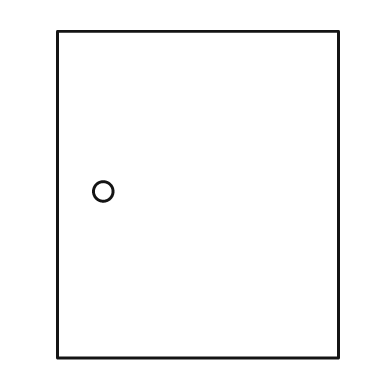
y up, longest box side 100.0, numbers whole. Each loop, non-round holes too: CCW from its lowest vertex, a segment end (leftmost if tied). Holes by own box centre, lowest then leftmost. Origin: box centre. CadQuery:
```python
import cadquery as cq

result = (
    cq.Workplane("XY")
    .moveTo(-43.0, -50.0)
    .lineTo(43.0, -50.0)
    .lineTo(43.0, 50.0)
    .lineTo(-43.0, 50.0)
    .close()
    .moveTo(-29.0, 1.0)
    .circle(3.0)
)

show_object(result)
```